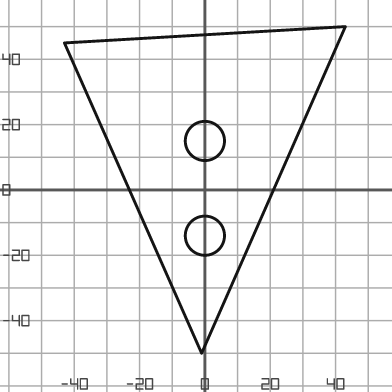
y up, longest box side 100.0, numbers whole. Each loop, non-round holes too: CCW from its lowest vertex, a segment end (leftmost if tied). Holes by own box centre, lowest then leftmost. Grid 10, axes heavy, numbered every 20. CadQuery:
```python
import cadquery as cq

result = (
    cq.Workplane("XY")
    .moveTo(-1.0, -50.0)
    .lineTo(43.0, 50.0)
    .lineTo(-43.0, 45.0)
    .close()
    .moveTo(0.0, -14.0)
    .circle(6.0)
    .moveTo(0.0, 15.0)
    .circle(6.0)
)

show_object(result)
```